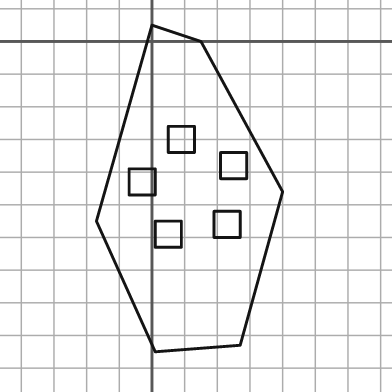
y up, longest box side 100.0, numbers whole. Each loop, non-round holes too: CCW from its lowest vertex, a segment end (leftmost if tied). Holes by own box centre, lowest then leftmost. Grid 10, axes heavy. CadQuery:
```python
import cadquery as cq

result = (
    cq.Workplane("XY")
    .moveTo(1.0, -95.0)
    .lineTo(27.0, -93.0)
    .lineTo(40.0, -46.0)
    .lineTo(15.0, 0.0)
    .lineTo(0.0, 5.0)
    .lineTo(-17.0, -55.0)
    .close()
    .moveTo(1.0, -63.0)
    .lineTo(9.0, -63.0)
    .lineTo(9.0, -55.0)
    .lineTo(1.0, -55.0)
    .close()
    .moveTo(19.0, -60.0)
    .lineTo(27.0, -60.0)
    .lineTo(27.0, -52.0)
    .lineTo(19.0, -52.0)
    .close()
    .moveTo(-7.0, -47.0)
    .lineTo(1.0, -47.0)
    .lineTo(1.0, -39.0)
    .lineTo(-7.0, -39.0)
    .close()
    .moveTo(21.0, -42.0)
    .lineTo(29.0, -42.0)
    .lineTo(29.0, -34.0)
    .lineTo(21.0, -34.0)
    .close()
    .moveTo(5.0, -34.0)
    .lineTo(13.0, -34.0)
    .lineTo(13.0, -26.0)
    .lineTo(5.0, -26.0)
    .close()
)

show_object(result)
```